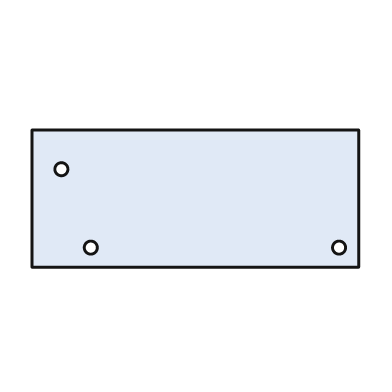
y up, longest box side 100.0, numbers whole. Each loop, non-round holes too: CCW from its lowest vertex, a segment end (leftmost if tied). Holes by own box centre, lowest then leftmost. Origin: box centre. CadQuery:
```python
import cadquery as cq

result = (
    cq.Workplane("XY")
    .moveTo(-50.0, -21.0)
    .lineTo(50.0, -21.0)
    .lineTo(50.0, 21.0)
    .lineTo(-50.0, 21.0)
    .close()
    .moveTo(-32.0, -15.0)
    .circle(2.0)
    .moveTo(44.0, -15.0)
    .circle(2.0)
    .moveTo(-41.0, 9.0)
    .circle(2.0)
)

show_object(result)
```